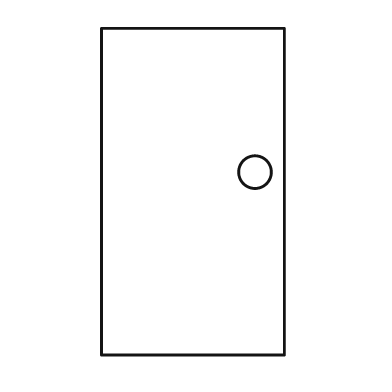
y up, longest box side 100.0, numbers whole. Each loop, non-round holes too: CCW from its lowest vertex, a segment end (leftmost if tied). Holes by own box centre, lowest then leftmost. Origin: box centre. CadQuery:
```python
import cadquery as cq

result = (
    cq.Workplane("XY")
    .moveTo(-28.0, -50.0)
    .lineTo(28.0, -50.0)
    .lineTo(28.0, 50.0)
    .lineTo(-28.0, 50.0)
    .close()
    .moveTo(19.0, 6.0)
    .circle(5.0)
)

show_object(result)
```